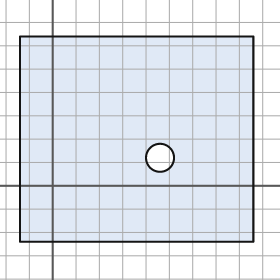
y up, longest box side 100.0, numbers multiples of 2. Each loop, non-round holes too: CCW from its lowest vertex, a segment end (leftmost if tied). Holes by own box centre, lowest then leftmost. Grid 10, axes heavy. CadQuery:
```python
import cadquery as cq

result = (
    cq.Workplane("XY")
    .moveTo(-14.0, -24.0)
    .lineTo(86.0, -24.0)
    .lineTo(86.0, 64.0)
    .lineTo(-14.0, 64.0)
    .close()
    .moveTo(46.0, 12.0)
    .circle(6.0)
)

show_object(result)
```